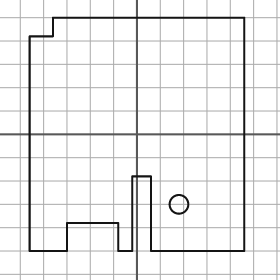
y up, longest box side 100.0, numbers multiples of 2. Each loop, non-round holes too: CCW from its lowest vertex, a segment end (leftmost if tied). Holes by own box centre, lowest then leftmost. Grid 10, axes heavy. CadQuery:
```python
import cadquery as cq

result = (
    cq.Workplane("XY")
    .moveTo(-46.0, -50.0)
    .lineTo(-30.0, -50.0)
    .lineTo(-30.0, -38.0)
    .lineTo(-8.0, -38.0)
    .lineTo(-8.0, -50.0)
    .lineTo(-2.0, -50.0)
    .lineTo(-2.0, -18.0)
    .lineTo(6.0, -18.0)
    .lineTo(6.0, -50.0)
    .lineTo(46.0, -50.0)
    .lineTo(46.0, 50.0)
    .lineTo(-36.0, 50.0)
    .lineTo(-36.0, 42.0)
    .lineTo(-46.0, 42.0)
    .close()
    .moveTo(18.0, -30.0)
    .circle(4.0)
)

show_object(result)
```